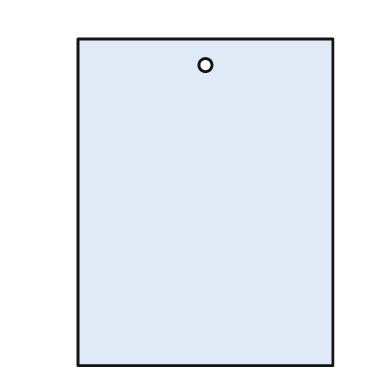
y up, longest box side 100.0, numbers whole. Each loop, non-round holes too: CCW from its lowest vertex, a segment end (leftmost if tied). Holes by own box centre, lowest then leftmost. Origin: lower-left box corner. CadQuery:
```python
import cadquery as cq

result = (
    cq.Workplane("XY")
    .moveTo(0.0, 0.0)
    .lineTo(78.0, 0.0)
    .lineTo(78.0, 100.0)
    .lineTo(0.0, 100.0)
    .close()
    .moveTo(39.0, 92.0)
    .circle(2.0)
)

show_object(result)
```